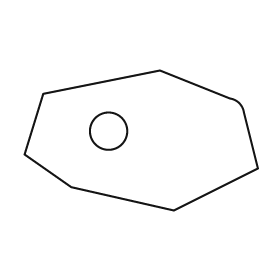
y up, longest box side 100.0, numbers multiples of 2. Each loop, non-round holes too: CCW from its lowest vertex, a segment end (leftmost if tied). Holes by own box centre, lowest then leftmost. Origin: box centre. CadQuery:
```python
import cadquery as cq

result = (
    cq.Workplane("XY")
    .moveTo(14.0, -30.0)
    .lineTo(50.0, -12.0)
    .lineTo(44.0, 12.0)
    .threePointArc((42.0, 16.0), (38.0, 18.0))
    .lineTo(8.0, 30.0)
    .lineTo(-42.0, 20.0)
    .lineTo(-50.0, -6.0)
    .lineTo(-30.0, -20.0)
    .close()
    .moveTo(-14.0, 4.0)
    .circle(8.0)
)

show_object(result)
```